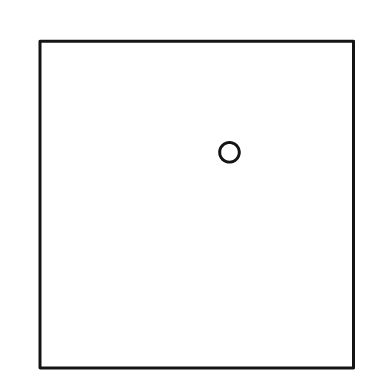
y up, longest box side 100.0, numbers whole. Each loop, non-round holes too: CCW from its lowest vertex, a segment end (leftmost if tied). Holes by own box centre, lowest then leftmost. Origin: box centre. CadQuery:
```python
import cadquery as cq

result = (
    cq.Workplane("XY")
    .moveTo(-48.0, -50.0)
    .lineTo(48.0, -50.0)
    .lineTo(48.0, 50.0)
    .lineTo(-48.0, 50.0)
    .close()
    .moveTo(10.0, 16.0)
    .circle(3.0)
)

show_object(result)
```